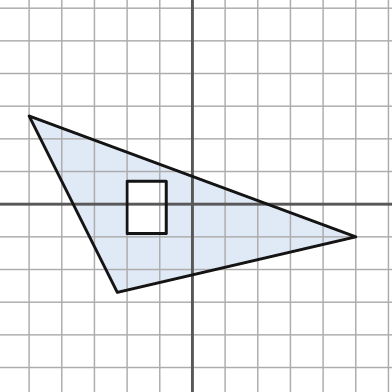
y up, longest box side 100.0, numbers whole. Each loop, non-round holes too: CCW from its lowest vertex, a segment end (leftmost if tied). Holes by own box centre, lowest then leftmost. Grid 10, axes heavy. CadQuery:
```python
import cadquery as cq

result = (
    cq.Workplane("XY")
    .moveTo(-23.0, -27.0)
    .lineTo(50.0, -10.0)
    .lineTo(-50.0, 27.0)
    .close()
    .moveTo(-20.0, -9.0)
    .lineTo(-8.0, -9.0)
    .lineTo(-8.0, 7.0)
    .lineTo(-20.0, 7.0)
    .close()
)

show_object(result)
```